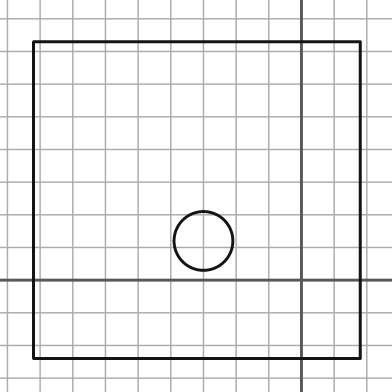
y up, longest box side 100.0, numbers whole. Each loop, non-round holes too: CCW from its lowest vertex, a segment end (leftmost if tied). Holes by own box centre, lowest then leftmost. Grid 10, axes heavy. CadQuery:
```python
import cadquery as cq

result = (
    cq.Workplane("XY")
    .moveTo(-82.0, -24.0)
    .lineTo(18.0, -24.0)
    .lineTo(18.0, 73.0)
    .lineTo(-82.0, 73.0)
    .close()
    .moveTo(-30.0, 12.0)
    .circle(9.0)
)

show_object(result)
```